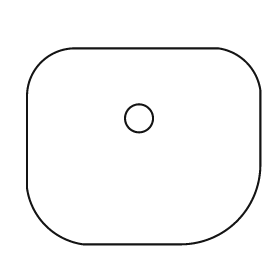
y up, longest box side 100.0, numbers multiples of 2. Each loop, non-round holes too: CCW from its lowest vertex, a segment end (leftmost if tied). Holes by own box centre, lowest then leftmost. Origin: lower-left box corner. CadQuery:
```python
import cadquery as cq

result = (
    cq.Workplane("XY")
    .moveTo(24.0, 0.0)
    .lineTo(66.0, 0.0)
    .threePointArc((90.0, 10.0), (100.0, 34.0))
    .lineTo(100.0, 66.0)
    .threePointArc((94.0, 78.0), (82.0, 84.0))
    .lineTo(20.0, 84.0)
    .threePointArc((6.0, 78.0), (0.0, 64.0))
    .lineTo(0.0, 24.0)
    .threePointArc((8.0, 8.0), (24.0, 0.0))
    .close()
    .moveTo(48.0, 54.0)
    .circle(6.0)
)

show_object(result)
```